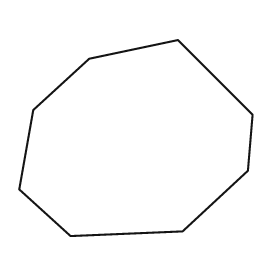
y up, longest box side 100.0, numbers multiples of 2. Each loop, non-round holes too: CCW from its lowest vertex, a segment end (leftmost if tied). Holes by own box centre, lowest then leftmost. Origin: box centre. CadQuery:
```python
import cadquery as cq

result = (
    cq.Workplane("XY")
    .moveTo(-28.0, -42.0)
    .lineTo(20.0, -40.0)
    .lineTo(48.0, -14.0)
    .lineTo(50.0, 10.0)
    .lineTo(18.0, 42.0)
    .lineTo(-20.0, 34.0)
    .lineTo(-44.0, 12.0)
    .lineTo(-50.0, -22.0)
    .close()
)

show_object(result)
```